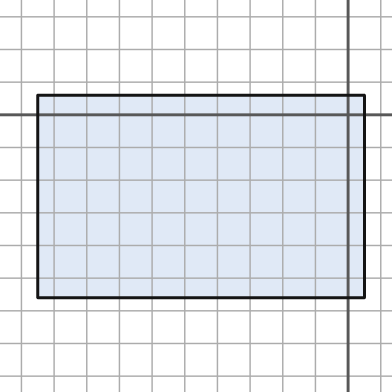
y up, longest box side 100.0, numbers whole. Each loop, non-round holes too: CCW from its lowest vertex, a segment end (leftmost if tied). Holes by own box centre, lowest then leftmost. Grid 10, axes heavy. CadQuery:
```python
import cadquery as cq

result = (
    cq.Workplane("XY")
    .moveTo(-95.0, -56.0)
    .lineTo(5.0, -56.0)
    .lineTo(5.0, 6.0)
    .lineTo(-95.0, 6.0)
    .close()
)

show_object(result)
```